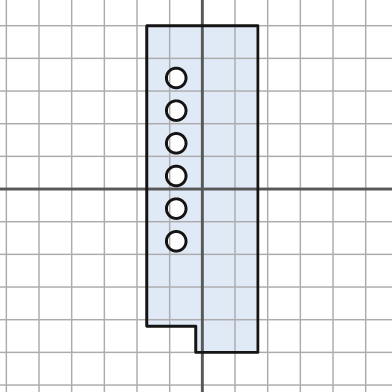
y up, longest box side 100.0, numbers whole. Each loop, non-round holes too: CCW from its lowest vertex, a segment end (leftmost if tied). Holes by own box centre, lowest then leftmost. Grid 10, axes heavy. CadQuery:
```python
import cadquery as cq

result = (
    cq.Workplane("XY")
    .moveTo(-2.0, -50.0)
    .lineTo(17.0, -50.0)
    .lineTo(17.0, 50.0)
    .lineTo(-17.0, 50.0)
    .lineTo(-17.0, -42.0)
    .lineTo(-2.0, -42.0)
    .close()
    .moveTo(-8.0, -16.0)
    .circle(3.0)
    .moveTo(-8.0, -6.0)
    .circle(3.0)
    .moveTo(-8.0, 4.0)
    .circle(3.0)
    .moveTo(-8.0, 14.0)
    .circle(3.0)
    .moveTo(-8.0, 24.0)
    .circle(3.0)
    .moveTo(-8.0, 34.0)
    .circle(3.0)
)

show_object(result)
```